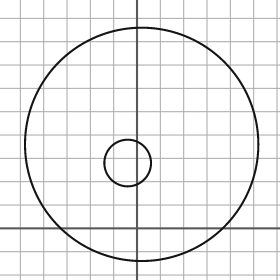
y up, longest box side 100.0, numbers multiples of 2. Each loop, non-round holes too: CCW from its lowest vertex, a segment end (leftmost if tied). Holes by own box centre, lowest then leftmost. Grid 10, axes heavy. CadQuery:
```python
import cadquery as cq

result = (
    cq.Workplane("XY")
    .moveTo(2.0, 36.0)
    .circle(50.0)
    .moveTo(-4.0, 28.0)
    .circle(10.0)
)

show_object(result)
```